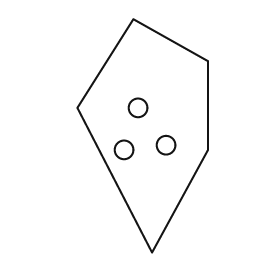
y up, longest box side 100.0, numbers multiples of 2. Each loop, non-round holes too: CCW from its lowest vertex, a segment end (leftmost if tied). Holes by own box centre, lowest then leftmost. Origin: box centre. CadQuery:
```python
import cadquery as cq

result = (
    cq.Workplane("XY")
    .moveTo(4.0, -50.0)
    .lineTo(28.0, -6.0)
    .lineTo(28.0, 32.0)
    .lineTo(-4.0, 50.0)
    .lineTo(-28.0, 12.0)
    .close()
    .moveTo(-8.0, -6.0)
    .circle(4.0)
    .moveTo(10.0, -4.0)
    .circle(4.0)
    .moveTo(-2.0, 12.0)
    .circle(4.0)
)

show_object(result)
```